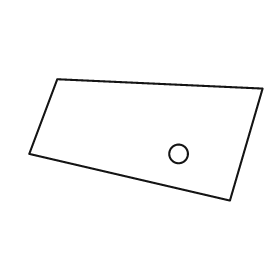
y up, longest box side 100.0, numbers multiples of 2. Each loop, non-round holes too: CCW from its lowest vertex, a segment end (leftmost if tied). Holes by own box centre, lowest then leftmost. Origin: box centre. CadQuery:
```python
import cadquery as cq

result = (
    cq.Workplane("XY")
    .moveTo(36.0, -26.0)
    .lineTo(50.0, 22.0)
    .lineTo(-38.0, 26.0)
    .lineTo(-50.0, -6.0)
    .close()
    .moveTo(14.0, -6.0)
    .circle(4.0)
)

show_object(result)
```